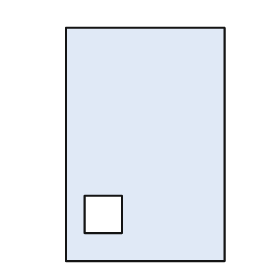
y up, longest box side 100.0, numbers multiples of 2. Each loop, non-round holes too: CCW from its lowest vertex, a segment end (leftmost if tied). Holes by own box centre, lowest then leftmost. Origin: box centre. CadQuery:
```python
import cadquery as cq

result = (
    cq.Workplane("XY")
    .moveTo(-34.0, -50.0)
    .lineTo(34.0, -50.0)
    .lineTo(34.0, 50.0)
    .lineTo(-34.0, 50.0)
    .close()
    .moveTo(-26.0, -38.0)
    .lineTo(-10.0, -38.0)
    .lineTo(-10.0, -22.0)
    .lineTo(-26.0, -22.0)
    .close()
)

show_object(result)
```